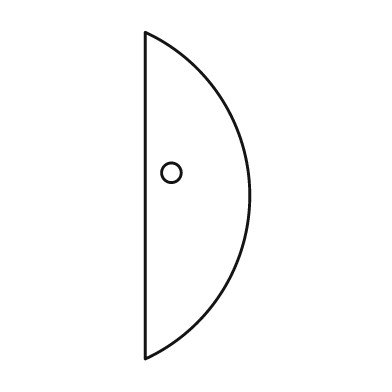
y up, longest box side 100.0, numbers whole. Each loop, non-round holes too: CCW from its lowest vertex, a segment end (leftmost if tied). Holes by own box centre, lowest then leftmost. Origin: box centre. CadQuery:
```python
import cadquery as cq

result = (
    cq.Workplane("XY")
    .moveTo(-16.0, -50.0)
    .threePointArc((16.0, 0.0), (-16.0, 50.0))
    .close()
    .moveTo(-8.0, 7.0)
    .circle(3.0)
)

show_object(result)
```